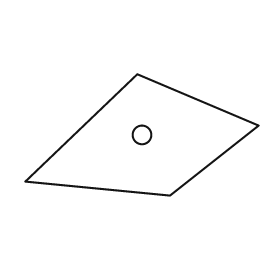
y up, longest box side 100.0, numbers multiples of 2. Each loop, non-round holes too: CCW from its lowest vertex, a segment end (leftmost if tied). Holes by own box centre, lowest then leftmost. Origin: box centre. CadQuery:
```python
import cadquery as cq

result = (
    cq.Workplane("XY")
    .moveTo(12.0, -26.0)
    .lineTo(50.0, 4.0)
    .lineTo(-2.0, 26.0)
    .lineTo(-50.0, -20.0)
    .close()
    .moveTo(0.0, 0.0)
    .circle(4.0)
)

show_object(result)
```